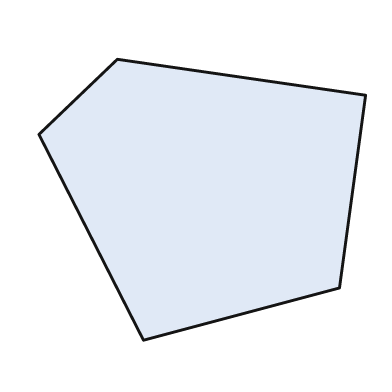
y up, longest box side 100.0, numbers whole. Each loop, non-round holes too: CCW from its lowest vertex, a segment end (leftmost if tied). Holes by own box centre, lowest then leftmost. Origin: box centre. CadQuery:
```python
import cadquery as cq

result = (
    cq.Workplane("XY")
    .moveTo(-18.0, -43.0)
    .lineTo(42.0, -27.0)
    .lineTo(50.0, 32.0)
    .lineTo(-26.0, 43.0)
    .lineTo(-50.0, 20.0)
    .close()
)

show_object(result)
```